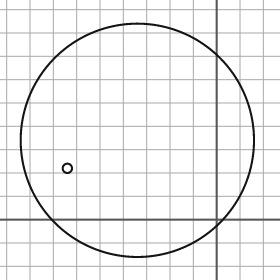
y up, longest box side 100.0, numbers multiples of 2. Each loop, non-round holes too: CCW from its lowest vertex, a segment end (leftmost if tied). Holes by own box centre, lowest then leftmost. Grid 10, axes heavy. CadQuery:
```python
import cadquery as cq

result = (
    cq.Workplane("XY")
    .moveTo(-34.0, 34.0)
    .circle(50.0)
    .moveTo(-64.0, 22.0)
    .circle(2.0)
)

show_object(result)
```